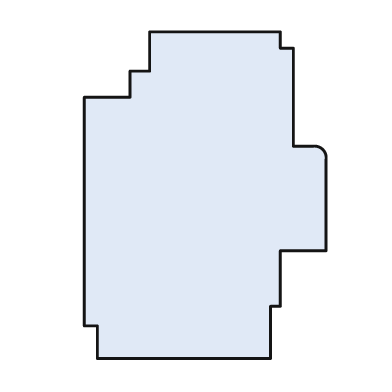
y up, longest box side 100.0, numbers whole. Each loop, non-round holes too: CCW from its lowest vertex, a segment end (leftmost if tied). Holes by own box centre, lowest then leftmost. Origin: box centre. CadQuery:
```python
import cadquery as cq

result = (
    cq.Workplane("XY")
    .moveTo(-33.0, -50.0)
    .lineTo(20.0, -50.0)
    .lineTo(20.0, -34.0)
    .lineTo(23.0, -34.0)
    .lineTo(23.0, -17.0)
    .lineTo(37.0, -17.0)
    .lineTo(37.0, 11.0)
    .threePointArc((36.0, 14.0), (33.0, 15.0))
    .lineTo(27.0, 15.0)
    .lineTo(27.0, 45.0)
    .lineTo(23.0, 45.0)
    .lineTo(23.0, 50.0)
    .lineTo(-17.0, 50.0)
    .lineTo(-17.0, 38.0)
    .lineTo(-23.0, 38.0)
    .lineTo(-23.0, 30.0)
    .lineTo(-37.0, 30.0)
    .lineTo(-37.0, -40.0)
    .lineTo(-33.0, -40.0)
    .close()
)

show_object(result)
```